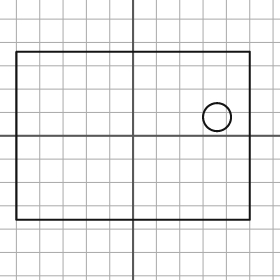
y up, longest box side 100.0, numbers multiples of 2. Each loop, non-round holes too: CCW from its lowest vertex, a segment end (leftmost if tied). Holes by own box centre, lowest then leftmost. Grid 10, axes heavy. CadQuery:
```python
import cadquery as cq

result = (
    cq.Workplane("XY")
    .moveTo(-50.0, -36.0)
    .lineTo(50.0, -36.0)
    .lineTo(50.0, 36.0)
    .lineTo(-50.0, 36.0)
    .close()
    .moveTo(36.0, 8.0)
    .circle(6.0)
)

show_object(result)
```